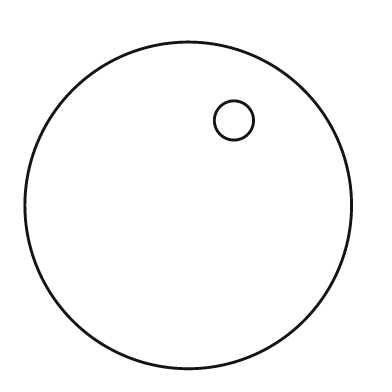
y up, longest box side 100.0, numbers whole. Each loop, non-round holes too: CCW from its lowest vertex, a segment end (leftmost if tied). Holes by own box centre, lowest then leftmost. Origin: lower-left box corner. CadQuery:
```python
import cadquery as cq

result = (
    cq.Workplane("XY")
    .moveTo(50.0, 50.0)
    .circle(50.0)
    .moveTo(64.0, 76.0)
    .circle(6.0)
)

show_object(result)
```